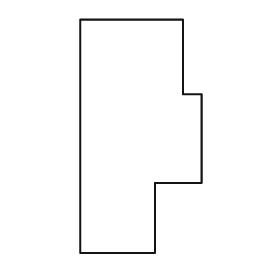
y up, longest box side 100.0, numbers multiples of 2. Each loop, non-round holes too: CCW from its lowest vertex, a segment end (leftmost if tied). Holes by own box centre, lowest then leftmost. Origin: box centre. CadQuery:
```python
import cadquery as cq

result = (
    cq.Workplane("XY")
    .moveTo(-26.0, -50.0)
    .lineTo(6.0, -50.0)
    .lineTo(6.0, -20.0)
    .lineTo(26.0, -20.0)
    .lineTo(26.0, 18.0)
    .lineTo(18.0, 18.0)
    .lineTo(18.0, 50.0)
    .lineTo(-26.0, 50.0)
    .close()
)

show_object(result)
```